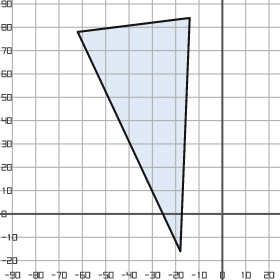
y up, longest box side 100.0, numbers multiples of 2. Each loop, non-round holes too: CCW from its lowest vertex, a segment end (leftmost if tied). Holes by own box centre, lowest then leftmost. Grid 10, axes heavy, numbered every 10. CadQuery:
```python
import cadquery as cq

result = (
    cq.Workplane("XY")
    .moveTo(-18.0, -16.0)
    .lineTo(-14.0, 84.0)
    .lineTo(-62.0, 78.0)
    .close()
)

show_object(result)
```